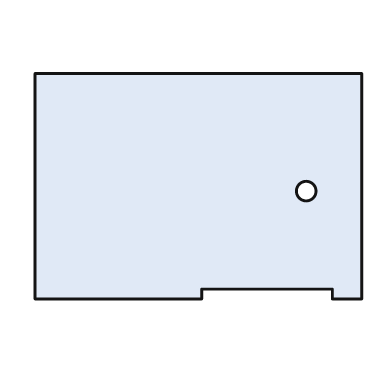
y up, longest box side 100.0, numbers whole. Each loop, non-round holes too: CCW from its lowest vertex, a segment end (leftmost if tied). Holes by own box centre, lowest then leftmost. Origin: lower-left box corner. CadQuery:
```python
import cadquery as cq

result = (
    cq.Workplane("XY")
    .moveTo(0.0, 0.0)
    .lineTo(51.0, 0.0)
    .lineTo(51.0, 3.0)
    .lineTo(91.0, 3.0)
    .lineTo(91.0, 0.0)
    .lineTo(100.0, 0.0)
    .lineTo(100.0, 69.0)
    .lineTo(0.0, 69.0)
    .close()
    .moveTo(83.0, 33.0)
    .circle(3.0)
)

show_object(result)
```